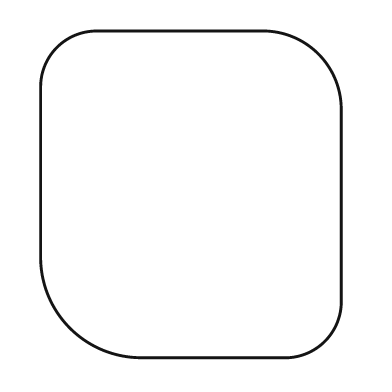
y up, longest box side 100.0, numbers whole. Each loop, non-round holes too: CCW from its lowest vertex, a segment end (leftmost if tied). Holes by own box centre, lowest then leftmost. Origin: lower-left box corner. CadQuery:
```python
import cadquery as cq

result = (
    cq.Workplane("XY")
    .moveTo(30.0, 0.0)
    .lineTo(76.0, 0.0)
    .threePointArc((87.0, 5.0), (92.0, 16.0))
    .lineTo(92.0, 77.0)
    .threePointArc((85.0, 93.0), (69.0, 100.0))
    .lineTo(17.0, 100.0)
    .threePointArc((5.0, 95.0), (0.0, 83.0))
    .lineTo(0.0, 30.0)
    .threePointArc((9.0, 9.0), (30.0, 0.0))
    .close()
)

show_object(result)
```